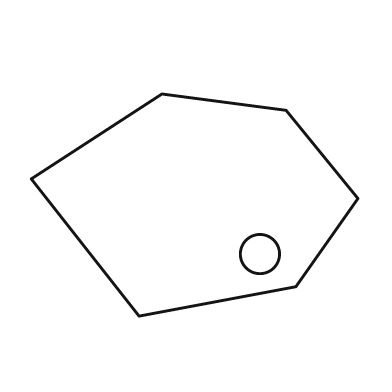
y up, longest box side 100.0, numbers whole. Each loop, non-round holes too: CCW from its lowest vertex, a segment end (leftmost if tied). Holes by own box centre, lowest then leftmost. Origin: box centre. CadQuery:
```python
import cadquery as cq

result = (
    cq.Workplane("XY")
    .moveTo(-17.0, -34.0)
    .lineTo(31.0, -25.0)
    .lineTo(50.0, 2.0)
    .lineTo(28.0, 29.0)
    .lineTo(-10.0, 34.0)
    .lineTo(-50.0, 8.0)
    .close()
    .moveTo(20.0, -15.0)
    .circle(6.0)
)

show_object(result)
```